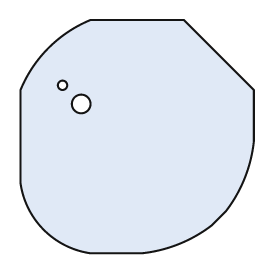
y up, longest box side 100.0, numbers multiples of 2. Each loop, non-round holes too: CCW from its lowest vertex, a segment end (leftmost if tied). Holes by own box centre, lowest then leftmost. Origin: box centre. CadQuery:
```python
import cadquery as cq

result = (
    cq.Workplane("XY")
    .moveTo(-20.0, -50.0)
    .lineTo(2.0, -50.0)
    .threePointArc((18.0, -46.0), (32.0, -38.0))
    .lineTo(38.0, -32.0)
    .threePointArc((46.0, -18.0), (50.0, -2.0))
    .lineTo(50.0, 20.0)
    .lineTo(20.0, 50.0)
    .lineTo(-20.0, 50.0)
    .threePointArc((-38.0, 38.0), (-50.0, 20.0))
    .lineTo(-50.0, -20.0)
    .threePointArc((-40.0, -40.0), (-20.0, -50.0))
    .close()
    .moveTo(-24.0, 14.0)
    .circle(4.0)
    .moveTo(-32.0, 22.0)
    .circle(2.0)
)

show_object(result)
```